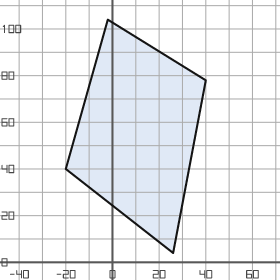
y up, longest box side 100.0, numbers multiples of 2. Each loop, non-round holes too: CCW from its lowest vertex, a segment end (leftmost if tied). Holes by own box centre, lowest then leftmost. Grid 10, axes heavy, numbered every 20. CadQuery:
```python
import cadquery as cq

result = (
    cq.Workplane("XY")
    .moveTo(26.0, 4.0)
    .lineTo(40.0, 78.0)
    .lineTo(-2.0, 104.0)
    .lineTo(-20.0, 40.0)
    .close()
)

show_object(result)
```